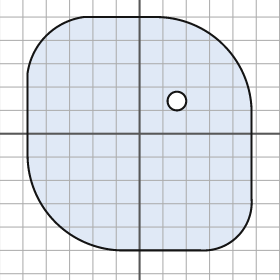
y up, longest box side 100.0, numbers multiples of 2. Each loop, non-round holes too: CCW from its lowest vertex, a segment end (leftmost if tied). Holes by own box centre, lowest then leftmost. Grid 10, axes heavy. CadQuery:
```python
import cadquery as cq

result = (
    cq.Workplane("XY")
    .moveTo(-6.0, -50.0)
    .lineTo(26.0, -50.0)
    .threePointArc((42.0, -44.0), (48.0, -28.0))
    .lineTo(48.0, 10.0)
    .threePointArc((36.0, 38.0), (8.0, 50.0))
    .lineTo(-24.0, 50.0)
    .threePointArc((-40.0, 42.0), (-48.0, 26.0))
    .lineTo(-48.0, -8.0)
    .threePointArc((-36.0, -38.0), (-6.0, -50.0))
    .close()
    .moveTo(16.0, 14.0)
    .circle(4.0)
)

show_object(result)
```